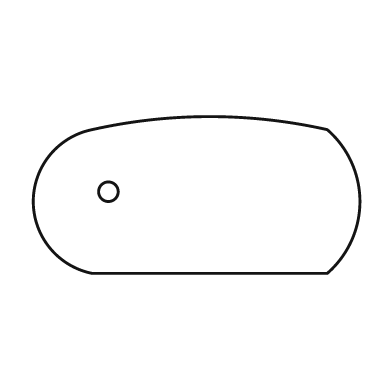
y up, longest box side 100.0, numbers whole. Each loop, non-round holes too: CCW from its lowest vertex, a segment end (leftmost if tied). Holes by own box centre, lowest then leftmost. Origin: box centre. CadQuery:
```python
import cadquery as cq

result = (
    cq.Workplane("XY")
    .moveTo(-32.0, -24.0)
    .lineTo(40.0, -24.0)
    .threePointArc((50.0, -2.0), (40.0, 20.0))
    .threePointArc((4.0, 24.0), (-32.0, 20.0))
    .threePointArc((-50.0, -2.0), (-32.0, -24.0))
    .close()
    .moveTo(-27.0, 1.0)
    .circle(3.0)
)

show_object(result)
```